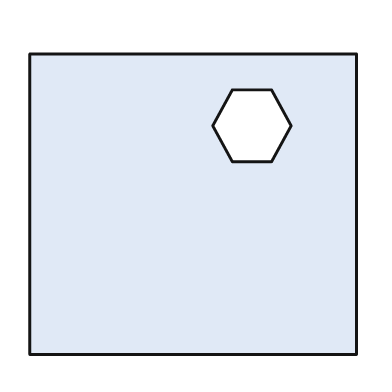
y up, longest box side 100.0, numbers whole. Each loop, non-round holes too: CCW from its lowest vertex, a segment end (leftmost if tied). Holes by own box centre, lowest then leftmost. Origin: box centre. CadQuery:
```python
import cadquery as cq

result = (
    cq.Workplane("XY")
    .moveTo(-50.0, -46.0)
    .lineTo(50.0, -46.0)
    .lineTo(50.0, 46.0)
    .lineTo(-50.0, 46.0)
    .close()
    .moveTo(12.0, 13.0)
    .lineTo(24.0, 13.0)
    .lineTo(30.0, 24.0)
    .lineTo(24.0, 35.0)
    .lineTo(12.0, 35.0)
    .lineTo(6.0, 24.0)
    .close()
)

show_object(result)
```